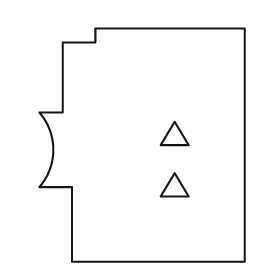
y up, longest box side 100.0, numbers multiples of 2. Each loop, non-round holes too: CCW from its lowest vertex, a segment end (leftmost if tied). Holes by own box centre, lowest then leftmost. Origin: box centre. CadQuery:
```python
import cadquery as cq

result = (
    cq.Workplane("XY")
    .moveTo(-30.0, -50.0)
    .lineTo(44.0, -50.0)
    .lineTo(44.0, 50.0)
    .lineTo(-20.0, 50.0)
    .lineTo(-20.0, 44.0)
    .lineTo(-34.0, 44.0)
    .lineTo(-34.0, 14.0)
    .lineTo(-44.0, 14.0)
    .threePointArc((-38.0, -2.0), (-44.0, -18.0))
    .lineTo(-30.0, -18.0)
    .close()
    .moveTo(8.0, -22.0)
    .lineTo(20.0, -22.0)
    .lineTo(14.0, -12.0)
    .close()
    .moveTo(8.0, 0.0)
    .lineTo(20.0, 0.0)
    .lineTo(14.0, 10.0)
    .close()
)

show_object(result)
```